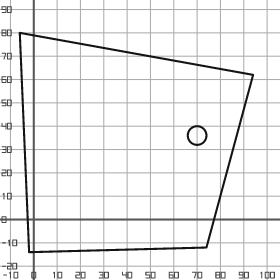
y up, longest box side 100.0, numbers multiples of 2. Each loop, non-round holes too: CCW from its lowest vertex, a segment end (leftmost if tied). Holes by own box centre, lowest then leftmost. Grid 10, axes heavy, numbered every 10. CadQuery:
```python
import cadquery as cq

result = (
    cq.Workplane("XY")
    .moveTo(-2.0, -14.0)
    .lineTo(74.0, -12.0)
    .lineTo(94.0, 62.0)
    .lineTo(-6.0, 80.0)
    .close()
    .moveTo(70.0, 36.0)
    .circle(4.0)
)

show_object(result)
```